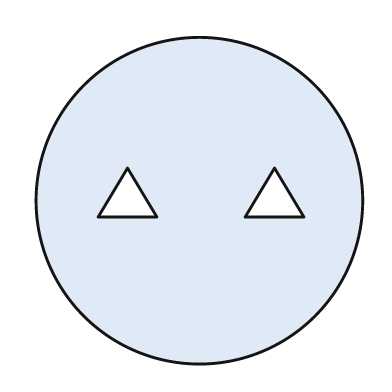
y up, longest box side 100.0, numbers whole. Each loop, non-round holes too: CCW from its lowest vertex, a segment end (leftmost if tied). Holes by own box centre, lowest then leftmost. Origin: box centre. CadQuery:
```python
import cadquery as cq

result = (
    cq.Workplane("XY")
    .moveTo(0.0, 0.0)
    .circle(50.0)
    .moveTo(-31.0, -5.0)
    .lineTo(-13.0, -5.0)
    .lineTo(-22.0, 10.0)
    .close()
    .moveTo(14.0, -5.0)
    .lineTo(32.0, -5.0)
    .lineTo(23.0, 10.0)
    .close()
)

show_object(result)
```